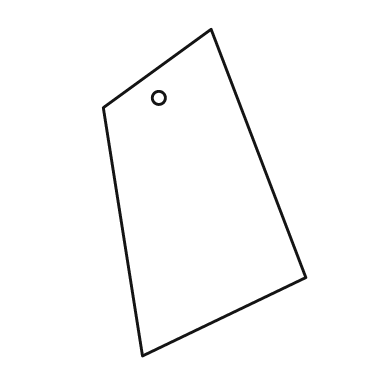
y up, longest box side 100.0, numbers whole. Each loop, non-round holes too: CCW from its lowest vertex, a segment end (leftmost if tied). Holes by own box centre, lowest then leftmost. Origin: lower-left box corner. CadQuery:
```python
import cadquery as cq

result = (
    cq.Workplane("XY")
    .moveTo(12.0, 0.0)
    .lineTo(62.0, 24.0)
    .lineTo(33.0, 100.0)
    .lineTo(0.0, 76.0)
    .close()
    .moveTo(17.0, 79.0)
    .circle(2.0)
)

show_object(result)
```